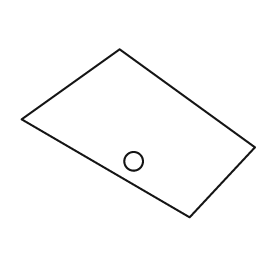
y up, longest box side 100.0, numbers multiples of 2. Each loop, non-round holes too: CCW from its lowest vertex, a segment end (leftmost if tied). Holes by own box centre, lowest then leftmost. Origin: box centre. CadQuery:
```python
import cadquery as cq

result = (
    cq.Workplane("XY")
    .moveTo(22.0, -36.0)
    .lineTo(50.0, -6.0)
    .lineTo(-8.0, 36.0)
    .lineTo(-50.0, 6.0)
    .close()
    .moveTo(-2.0, -12.0)
    .circle(4.0)
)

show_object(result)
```